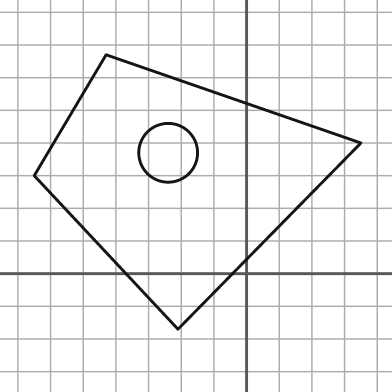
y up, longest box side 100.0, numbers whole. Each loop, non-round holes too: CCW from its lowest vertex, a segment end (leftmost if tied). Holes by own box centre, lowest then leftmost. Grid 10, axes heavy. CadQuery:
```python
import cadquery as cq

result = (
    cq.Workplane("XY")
    .moveTo(-21.0, -17.0)
    .lineTo(35.0, 40.0)
    .lineTo(-43.0, 67.0)
    .lineTo(-65.0, 30.0)
    .close()
    .moveTo(-24.0, 37.0)
    .circle(9.0)
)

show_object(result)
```